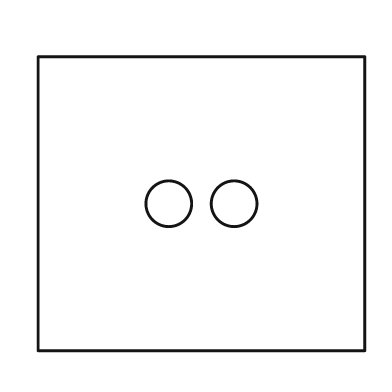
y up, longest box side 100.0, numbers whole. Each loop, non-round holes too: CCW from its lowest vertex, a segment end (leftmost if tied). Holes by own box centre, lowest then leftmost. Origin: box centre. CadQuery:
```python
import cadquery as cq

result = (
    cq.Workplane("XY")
    .moveTo(-50.0, -45.0)
    .lineTo(50.0, -45.0)
    .lineTo(50.0, 45.0)
    .lineTo(-50.0, 45.0)
    .close()
    .moveTo(-10.0, 0.0)
    .circle(7.0)
    .moveTo(10.0, 0.0)
    .circle(7.0)
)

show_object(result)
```